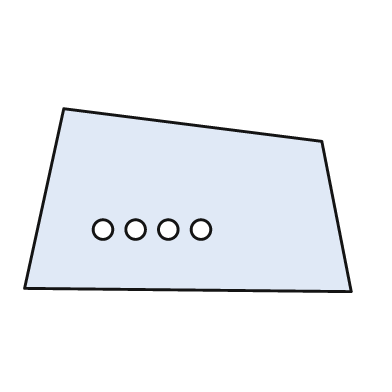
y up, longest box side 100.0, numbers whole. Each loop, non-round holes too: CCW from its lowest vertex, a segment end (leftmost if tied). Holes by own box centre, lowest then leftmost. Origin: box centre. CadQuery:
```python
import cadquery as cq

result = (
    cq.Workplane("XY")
    .moveTo(50.0, -28.0)
    .lineTo(41.0, 18.0)
    .lineTo(-38.0, 28.0)
    .lineTo(-50.0, -27.0)
    .close()
    .moveTo(-26.0, -9.0)
    .circle(3.0)
    .moveTo(-16.0, -9.0)
    .circle(3.0)
    .moveTo(-6.0, -9.0)
    .circle(3.0)
    .moveTo(4.0, -9.0)
    .circle(3.0)
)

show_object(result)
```